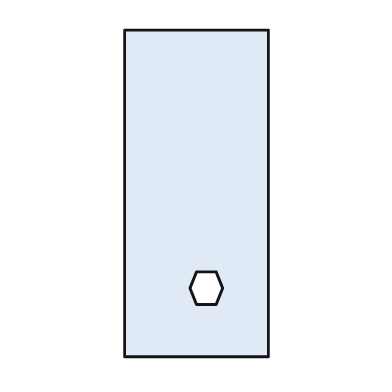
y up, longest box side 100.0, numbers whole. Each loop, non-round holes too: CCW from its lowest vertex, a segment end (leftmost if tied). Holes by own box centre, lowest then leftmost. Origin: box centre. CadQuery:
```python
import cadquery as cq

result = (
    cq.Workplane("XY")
    .moveTo(-22.0, -50.0)
    .lineTo(22.0, -50.0)
    .lineTo(22.0, 50.0)
    .lineTo(-22.0, 50.0)
    .close()
    .moveTo(0.0, -34.0)
    .lineTo(6.0, -34.0)
    .lineTo(8.0, -29.0)
    .lineTo(6.0, -24.0)
    .lineTo(0.0, -24.0)
    .lineTo(-2.0, -29.0)
    .close()
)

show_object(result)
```